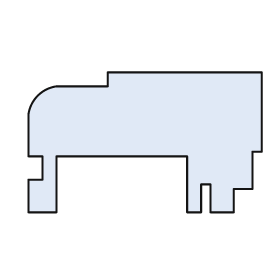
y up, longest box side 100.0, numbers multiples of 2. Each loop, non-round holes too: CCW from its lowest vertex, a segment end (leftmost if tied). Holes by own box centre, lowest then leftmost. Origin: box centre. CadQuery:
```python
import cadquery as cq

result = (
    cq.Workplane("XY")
    .moveTo(-50.0, -30.0)
    .lineTo(-38.0, -30.0)
    .lineTo(-38.0, -6.0)
    .lineTo(18.0, -6.0)
    .lineTo(18.0, -30.0)
    .lineTo(24.0, -30.0)
    .lineTo(24.0, -18.0)
    .lineTo(28.0, -18.0)
    .lineTo(28.0, -30.0)
    .lineTo(38.0, -30.0)
    .lineTo(38.0, -20.0)
    .lineTo(46.0, -20.0)
    .lineTo(46.0, -4.0)
    .lineTo(50.0, -4.0)
    .lineTo(50.0, 30.0)
    .lineTo(-16.0, 30.0)
    .lineTo(-16.0, 24.0)
    .lineTo(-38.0, 24.0)
    .threePointArc((-46.0, 20.0), (-50.0, 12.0))
    .lineTo(-50.0, -6.0)
    .lineTo(-44.0, -6.0)
    .lineTo(-44.0, -16.0)
    .lineTo(-50.0, -16.0)
    .close()
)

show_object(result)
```